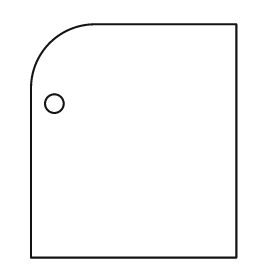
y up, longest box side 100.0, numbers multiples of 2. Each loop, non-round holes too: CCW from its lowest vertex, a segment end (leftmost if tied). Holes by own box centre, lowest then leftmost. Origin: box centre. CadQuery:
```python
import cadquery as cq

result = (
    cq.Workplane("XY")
    .moveTo(-44.0, -50.0)
    .lineTo(44.0, -50.0)
    .lineTo(44.0, 50.0)
    .lineTo(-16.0, 50.0)
    .threePointArc((-36.0, 42.0), (-44.0, 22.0))
    .close()
    .moveTo(-34.0, 16.0)
    .circle(4.0)
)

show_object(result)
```